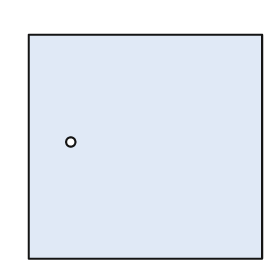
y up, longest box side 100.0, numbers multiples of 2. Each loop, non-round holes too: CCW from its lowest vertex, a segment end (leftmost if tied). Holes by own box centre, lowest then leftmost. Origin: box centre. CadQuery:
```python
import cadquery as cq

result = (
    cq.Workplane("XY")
    .moveTo(-50.0, -48.0)
    .lineTo(50.0, -48.0)
    .lineTo(50.0, 48.0)
    .lineTo(-50.0, 48.0)
    .close()
    .moveTo(-32.0, 2.0)
    .circle(2.0)
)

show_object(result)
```